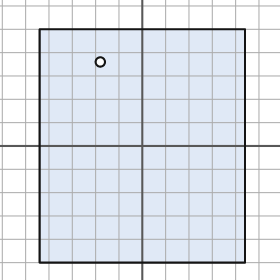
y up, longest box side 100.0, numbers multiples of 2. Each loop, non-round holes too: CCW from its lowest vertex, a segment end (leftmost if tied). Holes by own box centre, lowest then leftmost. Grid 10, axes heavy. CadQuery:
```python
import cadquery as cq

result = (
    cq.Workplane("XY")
    .moveTo(-44.0, -50.0)
    .lineTo(44.0, -50.0)
    .lineTo(44.0, 50.0)
    .lineTo(-44.0, 50.0)
    .close()
    .moveTo(-18.0, 36.0)
    .circle(2.0)
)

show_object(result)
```